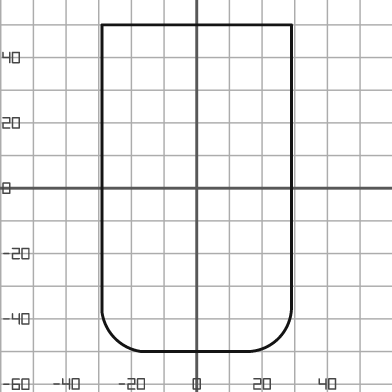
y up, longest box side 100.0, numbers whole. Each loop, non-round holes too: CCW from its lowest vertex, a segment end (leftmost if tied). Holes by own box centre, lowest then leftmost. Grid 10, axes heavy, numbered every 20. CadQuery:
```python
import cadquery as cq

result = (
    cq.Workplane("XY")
    .moveTo(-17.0, -50.0)
    .lineTo(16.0, -50.0)
    .threePointArc((25.0, -46.0), (29.0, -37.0))
    .lineTo(29.0, 50.0)
    .lineTo(-29.0, 50.0)
    .lineTo(-29.0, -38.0)
    .threePointArc((-25.0, -46.0), (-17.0, -50.0))
    .close()
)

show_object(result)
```